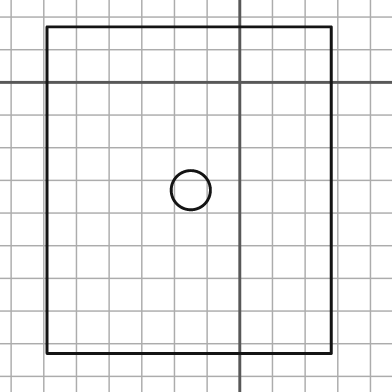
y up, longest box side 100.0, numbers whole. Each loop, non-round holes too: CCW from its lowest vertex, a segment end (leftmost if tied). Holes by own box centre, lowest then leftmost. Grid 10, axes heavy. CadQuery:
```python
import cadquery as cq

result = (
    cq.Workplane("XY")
    .moveTo(-59.0, -83.0)
    .lineTo(28.0, -83.0)
    .lineTo(28.0, 17.0)
    .lineTo(-59.0, 17.0)
    .close()
    .moveTo(-15.0, -33.0)
    .circle(6.0)
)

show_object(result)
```